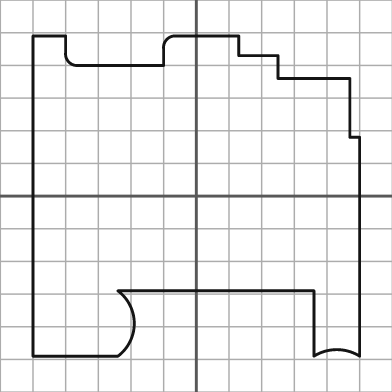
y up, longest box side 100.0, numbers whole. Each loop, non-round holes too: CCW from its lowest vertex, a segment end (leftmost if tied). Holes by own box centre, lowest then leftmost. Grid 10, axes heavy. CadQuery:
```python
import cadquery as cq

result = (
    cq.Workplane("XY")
    .moveTo(-50.0, -49.0)
    .lineTo(-24.0, -49.0)
    .threePointArc((-19.0, -39.0), (-24.0, -29.0))
    .lineTo(36.0, -29.0)
    .lineTo(36.0, -49.0)
    .threePointArc((43.0, -47.0), (50.0, -49.0))
    .lineTo(50.0, 18.0)
    .lineTo(47.0, 18.0)
    .lineTo(47.0, 36.0)
    .lineTo(25.0, 36.0)
    .lineTo(25.0, 43.0)
    .lineTo(13.0, 43.0)
    .lineTo(13.0, 49.0)
    .lineTo(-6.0, 49.0)
    .threePointArc((-9.0, 48.0), (-10.0, 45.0))
    .lineTo(-10.0, 40.0)
    .lineTo(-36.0, 40.0)
    .threePointArc((-39.0, 41.0), (-40.0, 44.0))
    .lineTo(-40.0, 49.0)
    .lineTo(-50.0, 49.0)
    .close()
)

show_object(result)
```